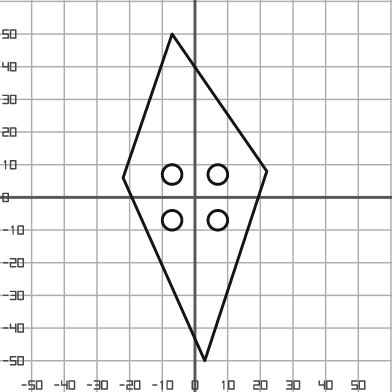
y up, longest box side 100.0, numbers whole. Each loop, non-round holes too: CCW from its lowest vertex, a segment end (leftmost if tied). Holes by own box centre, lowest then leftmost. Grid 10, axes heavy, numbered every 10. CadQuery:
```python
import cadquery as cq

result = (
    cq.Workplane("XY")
    .moveTo(3.0, -50.0)
    .lineTo(22.0, 8.0)
    .lineTo(-7.0, 50.0)
    .lineTo(-22.0, 6.0)
    .close()
    .moveTo(-7.0, -7.0)
    .circle(3.0)
    .moveTo(7.0, -7.0)
    .circle(3.0)
    .moveTo(-7.0, 7.0)
    .circle(3.0)
    .moveTo(7.0, 7.0)
    .circle(3.0)
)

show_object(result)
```